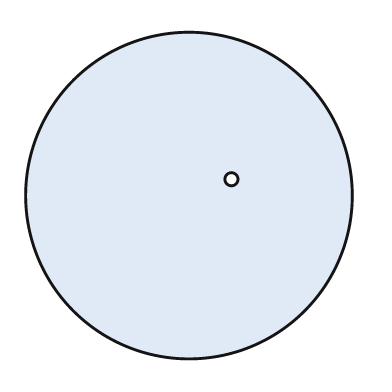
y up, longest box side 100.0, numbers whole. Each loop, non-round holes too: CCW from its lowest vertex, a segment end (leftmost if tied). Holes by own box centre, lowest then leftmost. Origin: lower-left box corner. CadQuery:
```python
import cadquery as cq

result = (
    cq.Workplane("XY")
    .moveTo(50.0, 50.0)
    .circle(50.0)
    .moveTo(63.0, 55.0)
    .circle(2.0)
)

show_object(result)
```